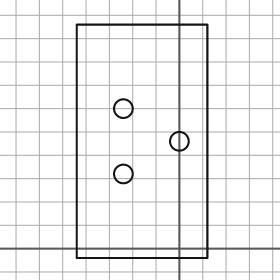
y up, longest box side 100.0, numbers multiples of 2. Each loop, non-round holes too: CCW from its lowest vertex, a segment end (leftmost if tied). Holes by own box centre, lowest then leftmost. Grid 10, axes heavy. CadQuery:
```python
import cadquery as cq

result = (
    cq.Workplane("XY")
    .moveTo(-44.0, -4.0)
    .lineTo(12.0, -4.0)
    .lineTo(12.0, 96.0)
    .lineTo(-44.0, 96.0)
    .close()
    .moveTo(-24.0, 32.0)
    .circle(4.0)
    .moveTo(0.0, 46.0)
    .circle(4.0)
    .moveTo(-24.0, 60.0)
    .circle(4.0)
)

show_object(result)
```